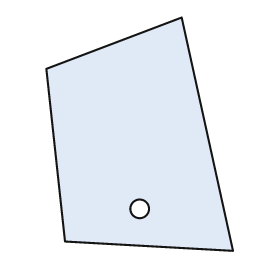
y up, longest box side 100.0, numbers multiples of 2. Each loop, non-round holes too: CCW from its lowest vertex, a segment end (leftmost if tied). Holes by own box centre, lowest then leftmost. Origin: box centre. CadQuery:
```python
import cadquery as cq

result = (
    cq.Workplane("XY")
    .moveTo(40.0, -50.0)
    .lineTo(18.0, 50.0)
    .lineTo(-40.0, 28.0)
    .lineTo(-32.0, -46.0)
    .close()
    .moveTo(0.0, -32.0)
    .circle(4.0)
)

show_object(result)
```